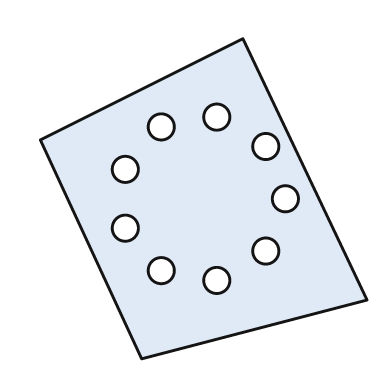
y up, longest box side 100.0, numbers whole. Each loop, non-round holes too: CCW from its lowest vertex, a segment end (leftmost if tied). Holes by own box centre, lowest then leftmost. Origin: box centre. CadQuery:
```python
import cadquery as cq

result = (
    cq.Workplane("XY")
    .moveTo(-19.0, -49.0)
    .lineTo(50.0, -31.0)
    .lineTo(12.0, 49.0)
    .lineTo(-50.0, 18.0)
    .close()
    .moveTo(4.0, -25.0)
    .circle(4.0)
    .moveTo(-13.0, -22.0)
    .circle(4.0)
    .moveTo(19.0, -16.0)
    .circle(4.0)
    .moveTo(-24.0, -9.0)
    .circle(4.0)
    .moveTo(25.0, 0.0)
    .circle(4.0)
    .moveTo(-24.0, 9.0)
    .circle(4.0)
    .moveTo(19.0, 16.0)
    .circle(4.0)
    .moveTo(-13.0, 22.0)
    .circle(4.0)
    .moveTo(4.0, 25.0)
    .circle(4.0)
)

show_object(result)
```